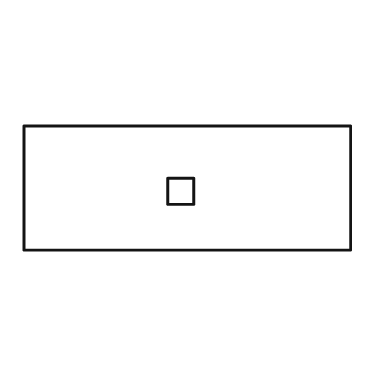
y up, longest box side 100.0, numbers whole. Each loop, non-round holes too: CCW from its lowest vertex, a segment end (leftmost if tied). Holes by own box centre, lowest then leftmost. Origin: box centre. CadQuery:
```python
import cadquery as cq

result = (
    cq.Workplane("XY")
    .moveTo(-50.0, -19.0)
    .lineTo(50.0, -19.0)
    .lineTo(50.0, 19.0)
    .lineTo(-50.0, 19.0)
    .close()
    .moveTo(-6.0, -5.0)
    .lineTo(2.0, -5.0)
    .lineTo(2.0, 3.0)
    .lineTo(-6.0, 3.0)
    .close()
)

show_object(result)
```